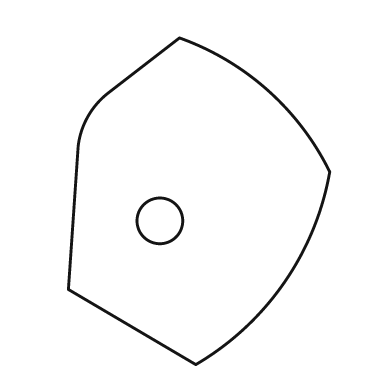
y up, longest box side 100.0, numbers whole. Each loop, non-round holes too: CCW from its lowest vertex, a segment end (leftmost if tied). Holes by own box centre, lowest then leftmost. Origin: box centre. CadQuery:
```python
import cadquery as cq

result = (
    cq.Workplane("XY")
    .moveTo(-1.0, -50.0)
    .threePointArc((26.0, -25.0), (40.0, 9.0))
    .threePointArc((21.0, 34.0), (-6.0, 50.0))
    .lineTo(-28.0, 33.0)
    .threePointArc((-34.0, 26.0), (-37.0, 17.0))
    .lineTo(-40.0, -27.0)
    .close()
    .moveTo(-12.0, -6.0)
    .circle(7.0)
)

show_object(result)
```